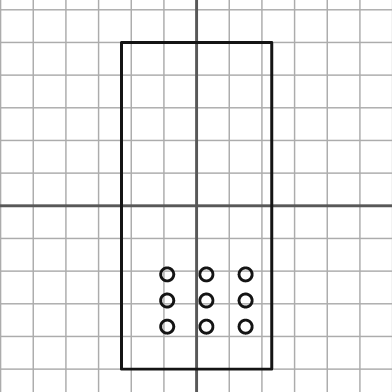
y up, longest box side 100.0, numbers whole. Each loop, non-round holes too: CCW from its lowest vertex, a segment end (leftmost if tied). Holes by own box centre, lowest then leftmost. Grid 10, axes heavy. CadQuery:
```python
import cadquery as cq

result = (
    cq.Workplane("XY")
    .moveTo(-23.0, -50.0)
    .lineTo(23.0, -50.0)
    .lineTo(23.0, 50.0)
    .lineTo(-23.0, 50.0)
    .close()
    .moveTo(-9.0, -37.0)
    .circle(2.0)
    .moveTo(3.0, -37.0)
    .circle(2.0)
    .moveTo(15.0, -37.0)
    .circle(2.0)
    .moveTo(-9.0, -29.0)
    .circle(2.0)
    .moveTo(3.0, -29.0)
    .circle(2.0)
    .moveTo(15.0, -29.0)
    .circle(2.0)
    .moveTo(-9.0, -21.0)
    .circle(2.0)
    .moveTo(3.0, -21.0)
    .circle(2.0)
    .moveTo(15.0, -21.0)
    .circle(2.0)
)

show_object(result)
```